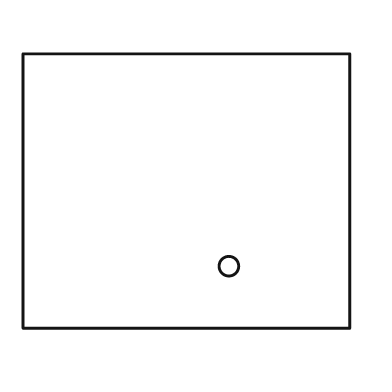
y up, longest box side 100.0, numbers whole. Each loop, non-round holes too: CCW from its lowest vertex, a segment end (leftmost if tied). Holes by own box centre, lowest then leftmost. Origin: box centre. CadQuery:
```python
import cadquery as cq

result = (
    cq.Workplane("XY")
    .moveTo(-50.0, -42.0)
    .lineTo(50.0, -42.0)
    .lineTo(50.0, 42.0)
    .lineTo(-50.0, 42.0)
    .close()
    .moveTo(13.0, -23.0)
    .circle(3.0)
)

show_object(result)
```